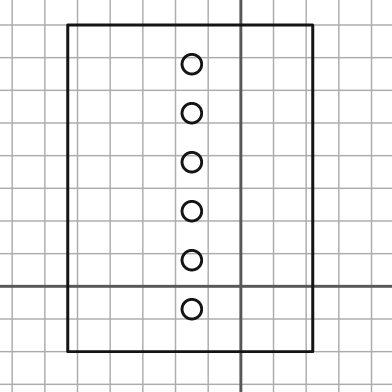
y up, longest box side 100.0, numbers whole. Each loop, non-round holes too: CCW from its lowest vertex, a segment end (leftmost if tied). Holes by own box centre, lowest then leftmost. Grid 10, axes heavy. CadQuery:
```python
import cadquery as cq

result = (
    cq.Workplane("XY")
    .moveTo(-53.0, -20.0)
    .lineTo(22.0, -20.0)
    .lineTo(22.0, 80.0)
    .lineTo(-53.0, 80.0)
    .close()
    .moveTo(-15.0, -7.0)
    .circle(3.0)
    .moveTo(-15.0, 8.0)
    .circle(3.0)
    .moveTo(-15.0, 23.0)
    .circle(3.0)
    .moveTo(-15.0, 38.0)
    .circle(3.0)
    .moveTo(-15.0, 53.0)
    .circle(3.0)
    .moveTo(-15.0, 68.0)
    .circle(3.0)
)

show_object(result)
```